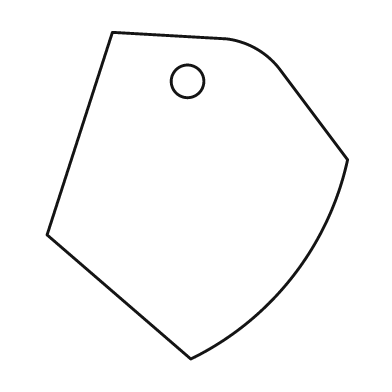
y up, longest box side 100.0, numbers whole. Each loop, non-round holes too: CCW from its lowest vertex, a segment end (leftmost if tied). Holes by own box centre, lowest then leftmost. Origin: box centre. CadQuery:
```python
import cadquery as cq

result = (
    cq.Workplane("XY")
    .moveTo(-2.0, -50.0)
    .threePointArc((29.0, -25.0), (46.0, 11.0))
    .lineTo(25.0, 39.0)
    .threePointArc((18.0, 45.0), (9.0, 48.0))
    .lineTo(-26.0, 50.0)
    .lineTo(-46.0, -12.0)
    .close()
    .moveTo(-3.0, 35.0)
    .circle(5.0)
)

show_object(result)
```